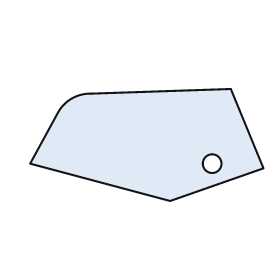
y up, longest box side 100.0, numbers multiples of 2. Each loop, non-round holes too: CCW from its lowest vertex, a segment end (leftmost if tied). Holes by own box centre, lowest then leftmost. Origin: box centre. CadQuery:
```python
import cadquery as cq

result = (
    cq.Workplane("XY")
    .moveTo(10.0, -24.0)
    .lineTo(50.0, -10.0)
    .lineTo(36.0, 24.0)
    .lineTo(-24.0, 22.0)
    .threePointArc((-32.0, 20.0), (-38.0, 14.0))
    .lineTo(-50.0, -8.0)
    .close()
    .moveTo(28.0, -8.0)
    .circle(4.0)
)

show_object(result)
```